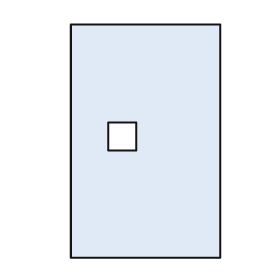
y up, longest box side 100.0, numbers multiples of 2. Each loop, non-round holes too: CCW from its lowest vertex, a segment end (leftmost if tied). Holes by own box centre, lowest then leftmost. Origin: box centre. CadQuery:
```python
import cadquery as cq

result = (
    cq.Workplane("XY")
    .moveTo(-32.0, -50.0)
    .lineTo(32.0, -50.0)
    .lineTo(32.0, 50.0)
    .lineTo(-32.0, 50.0)
    .close()
    .moveTo(-16.0, -4.0)
    .lineTo(-4.0, -4.0)
    .lineTo(-4.0, 8.0)
    .lineTo(-16.0, 8.0)
    .close()
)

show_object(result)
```